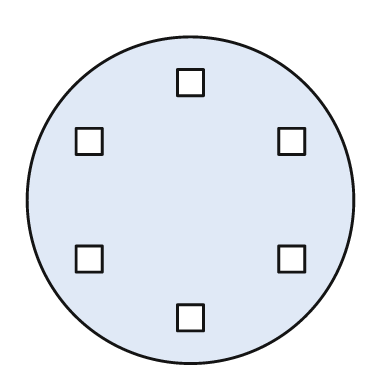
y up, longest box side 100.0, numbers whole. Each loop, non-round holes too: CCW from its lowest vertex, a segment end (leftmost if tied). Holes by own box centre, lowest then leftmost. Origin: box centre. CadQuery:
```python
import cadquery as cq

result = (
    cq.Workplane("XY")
    .moveTo(0.0, 0.0)
    .circle(50.0)
    .moveTo(-4.0, -40.0)
    .lineTo(4.0, -40.0)
    .lineTo(4.0, -32.0)
    .lineTo(-4.0, -32.0)
    .close()
    .moveTo(-35.0, -22.0)
    .lineTo(-27.0, -22.0)
    .lineTo(-27.0, -14.0)
    .lineTo(-35.0, -14.0)
    .close()
    .moveTo(27.0, -22.0)
    .lineTo(35.0, -22.0)
    .lineTo(35.0, -14.0)
    .lineTo(27.0, -14.0)
    .close()
    .moveTo(-35.0, 14.0)
    .lineTo(-27.0, 14.0)
    .lineTo(-27.0, 22.0)
    .lineTo(-35.0, 22.0)
    .close()
    .moveTo(27.0, 14.0)
    .lineTo(35.0, 14.0)
    .lineTo(35.0, 22.0)
    .lineTo(27.0, 22.0)
    .close()
    .moveTo(-4.0, 32.0)
    .lineTo(4.0, 32.0)
    .lineTo(4.0, 40.0)
    .lineTo(-4.0, 40.0)
    .close()
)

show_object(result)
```